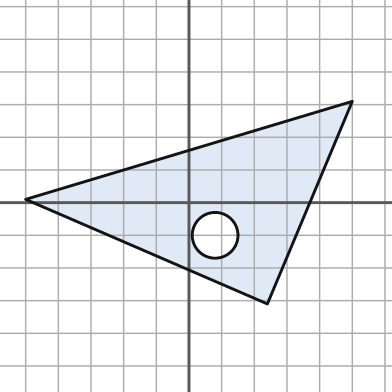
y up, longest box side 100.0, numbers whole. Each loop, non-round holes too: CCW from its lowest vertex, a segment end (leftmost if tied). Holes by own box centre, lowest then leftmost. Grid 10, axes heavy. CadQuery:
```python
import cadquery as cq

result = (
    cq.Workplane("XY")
    .moveTo(24.0, -31.0)
    .lineTo(50.0, 31.0)
    .lineTo(-50.0, 1.0)
    .close()
    .moveTo(8.0, -10.0)
    .circle(7.0)
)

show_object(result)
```